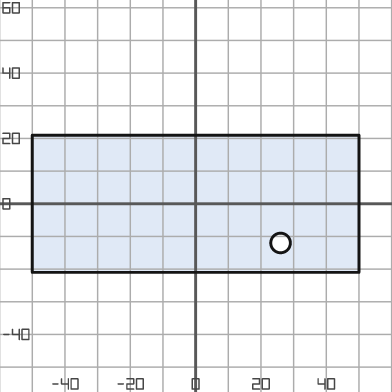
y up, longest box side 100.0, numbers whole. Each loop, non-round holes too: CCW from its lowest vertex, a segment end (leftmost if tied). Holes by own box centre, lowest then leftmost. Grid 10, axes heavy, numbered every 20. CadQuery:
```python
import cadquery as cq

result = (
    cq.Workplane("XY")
    .moveTo(-50.0, -21.0)
    .lineTo(50.0, -21.0)
    .lineTo(50.0, 21.0)
    .lineTo(-50.0, 21.0)
    .close()
    .moveTo(26.0, -12.0)
    .circle(3.0)
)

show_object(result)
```